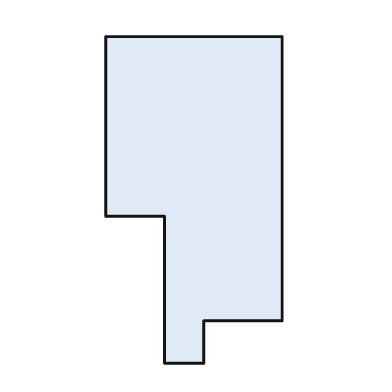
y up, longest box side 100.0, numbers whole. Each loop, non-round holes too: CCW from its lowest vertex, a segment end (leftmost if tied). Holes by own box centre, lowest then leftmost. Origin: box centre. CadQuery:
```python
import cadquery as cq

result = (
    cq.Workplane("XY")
    .moveTo(-9.0, -50.0)
    .lineTo(3.0, -50.0)
    .lineTo(3.0, -37.0)
    .lineTo(27.0, -37.0)
    .lineTo(27.0, 50.0)
    .lineTo(-27.0, 50.0)
    .lineTo(-27.0, -5.0)
    .lineTo(-9.0, -5.0)
    .close()
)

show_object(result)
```